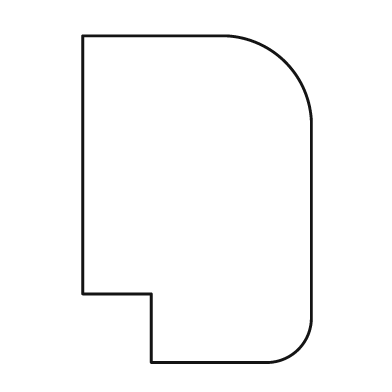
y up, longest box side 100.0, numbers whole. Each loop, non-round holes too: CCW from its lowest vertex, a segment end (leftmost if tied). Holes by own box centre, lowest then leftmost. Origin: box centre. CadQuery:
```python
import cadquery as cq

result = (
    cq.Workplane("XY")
    .moveTo(-14.0, -50.0)
    .lineTo(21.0, -50.0)
    .threePointArc((31.0, -46.0), (35.0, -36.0))
    .lineTo(35.0, 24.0)
    .threePointArc((27.0, 42.0), (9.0, 50.0))
    .lineTo(-35.0, 50.0)
    .lineTo(-35.0, -29.0)
    .lineTo(-14.0, -29.0)
    .close()
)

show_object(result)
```